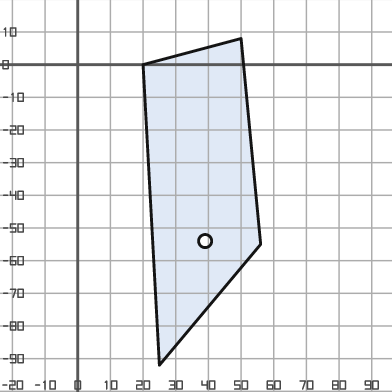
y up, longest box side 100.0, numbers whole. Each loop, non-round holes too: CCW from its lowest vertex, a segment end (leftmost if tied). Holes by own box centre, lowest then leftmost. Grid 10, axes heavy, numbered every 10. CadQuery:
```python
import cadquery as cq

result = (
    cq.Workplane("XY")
    .moveTo(25.0, -92.0)
    .lineTo(56.0, -55.0)
    .lineTo(50.0, 8.0)
    .lineTo(20.0, 0.0)
    .close()
    .moveTo(39.0, -54.0)
    .circle(2.0)
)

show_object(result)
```